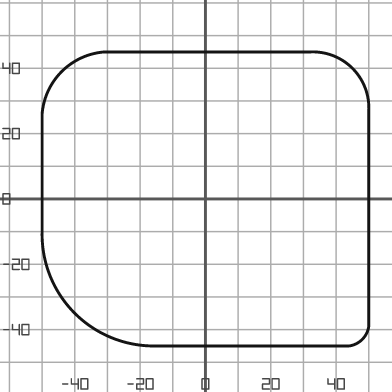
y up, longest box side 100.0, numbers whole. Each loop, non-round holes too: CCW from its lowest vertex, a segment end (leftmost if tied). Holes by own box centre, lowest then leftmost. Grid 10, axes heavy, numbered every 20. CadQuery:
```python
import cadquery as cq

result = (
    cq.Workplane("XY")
    .moveTo(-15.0, -45.0)
    .lineTo(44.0, -45.0)
    .threePointArc((48.0, -43.0), (50.0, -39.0))
    .lineTo(50.0, 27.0)
    .threePointArc((45.0, 40.0), (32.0, 45.0))
    .lineTo(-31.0, 45.0)
    .threePointArc((-44.0, 39.0), (-50.0, 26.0))
    .lineTo(-50.0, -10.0)
    .threePointArc((-40.0, -35.0), (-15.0, -45.0))
    .close()
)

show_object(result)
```